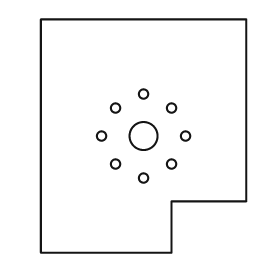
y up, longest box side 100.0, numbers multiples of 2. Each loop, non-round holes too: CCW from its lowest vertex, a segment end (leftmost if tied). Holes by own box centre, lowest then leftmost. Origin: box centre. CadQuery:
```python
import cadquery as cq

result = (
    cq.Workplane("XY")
    .moveTo(-44.0, -50.0)
    .lineTo(12.0, -50.0)
    .lineTo(12.0, -28.0)
    .lineTo(44.0, -28.0)
    .lineTo(44.0, 50.0)
    .lineTo(-44.0, 50.0)
    .close()
    .moveTo(0.0, -18.0)
    .circle(2.0)
    .moveTo(-12.0, -12.0)
    .circle(2.0)
    .moveTo(12.0, -12.0)
    .circle(2.0)
    .moveTo(-18.0, 0.0)
    .circle(2.0)
    .moveTo(0.0, 0.0)
    .circle(6.0)
    .moveTo(18.0, 0.0)
    .circle(2.0)
    .moveTo(-12.0, 12.0)
    .circle(2.0)
    .moveTo(12.0, 12.0)
    .circle(2.0)
    .moveTo(0.0, 18.0)
    .circle(2.0)
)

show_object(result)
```